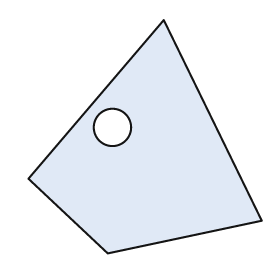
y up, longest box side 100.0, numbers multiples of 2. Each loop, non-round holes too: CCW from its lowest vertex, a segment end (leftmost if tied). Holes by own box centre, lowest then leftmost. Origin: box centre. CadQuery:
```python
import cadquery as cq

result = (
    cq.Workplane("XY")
    .moveTo(-16.0, -50.0)
    .lineTo(50.0, -36.0)
    .lineTo(8.0, 50.0)
    .lineTo(-50.0, -18.0)
    .close()
    .moveTo(-14.0, 4.0)
    .circle(8.0)
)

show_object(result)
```